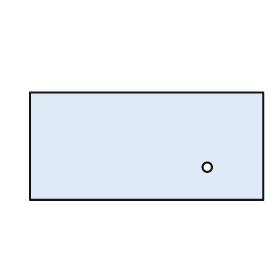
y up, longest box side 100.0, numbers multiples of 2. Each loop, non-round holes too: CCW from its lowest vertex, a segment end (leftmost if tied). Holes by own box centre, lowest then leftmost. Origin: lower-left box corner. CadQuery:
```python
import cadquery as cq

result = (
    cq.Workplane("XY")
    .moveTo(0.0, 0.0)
    .lineTo(100.0, 0.0)
    .lineTo(100.0, 46.0)
    .lineTo(0.0, 46.0)
    .close()
    .moveTo(76.0, 14.0)
    .circle(2.0)
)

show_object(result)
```